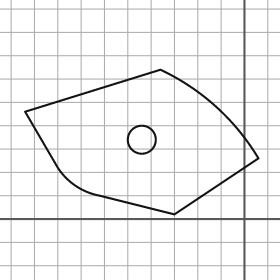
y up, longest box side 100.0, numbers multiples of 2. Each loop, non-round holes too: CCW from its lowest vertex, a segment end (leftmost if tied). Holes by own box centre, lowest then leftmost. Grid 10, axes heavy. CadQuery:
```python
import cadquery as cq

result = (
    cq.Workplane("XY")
    .moveTo(-30.0, 2.0)
    .lineTo(6.0, 26.0)
    .threePointArc((-12.0, 48.0), (-36.0, 64.0))
    .lineTo(-94.0, 46.0)
    .lineTo(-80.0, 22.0)
    .threePointArc((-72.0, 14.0), (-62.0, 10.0))
    .close()
    .moveTo(-44.0, 34.0)
    .circle(6.0)
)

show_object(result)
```